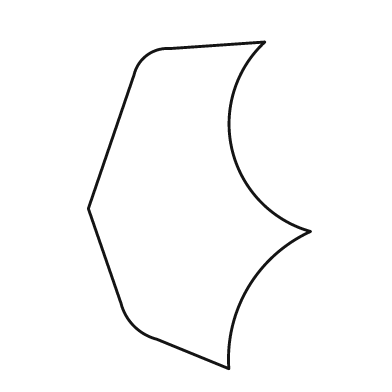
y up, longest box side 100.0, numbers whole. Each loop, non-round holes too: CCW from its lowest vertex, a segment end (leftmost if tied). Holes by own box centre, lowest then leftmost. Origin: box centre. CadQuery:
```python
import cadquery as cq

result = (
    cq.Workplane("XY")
    .moveTo(9.0, -50.0)
    .threePointArc((15.0, -25.0), (34.0, -8.0))
    .threePointArc((10.0, 17.0), (20.0, 50.0))
    .lineTo(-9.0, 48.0)
    .threePointArc((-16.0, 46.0), (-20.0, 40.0))
    .lineTo(-34.0, -1.0)
    .lineTo(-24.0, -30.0)
    .threePointArc((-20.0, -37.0), (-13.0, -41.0))
    .close()
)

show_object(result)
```